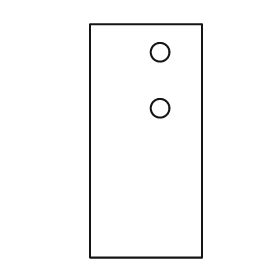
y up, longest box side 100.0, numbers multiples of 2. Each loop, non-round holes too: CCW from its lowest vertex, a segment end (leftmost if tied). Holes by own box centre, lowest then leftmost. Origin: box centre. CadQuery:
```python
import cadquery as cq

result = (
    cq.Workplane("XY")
    .moveTo(-24.0, -50.0)
    .lineTo(24.0, -50.0)
    .lineTo(24.0, 50.0)
    .lineTo(-24.0, 50.0)
    .close()
    .moveTo(6.0, 14.0)
    .circle(4.0)
    .moveTo(6.0, 38.0)
    .circle(4.0)
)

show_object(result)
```